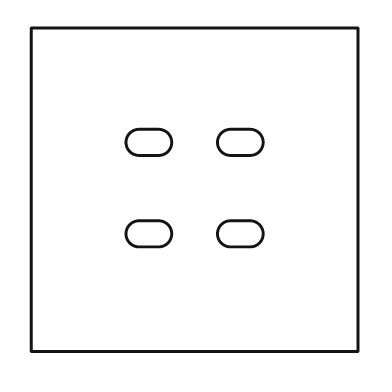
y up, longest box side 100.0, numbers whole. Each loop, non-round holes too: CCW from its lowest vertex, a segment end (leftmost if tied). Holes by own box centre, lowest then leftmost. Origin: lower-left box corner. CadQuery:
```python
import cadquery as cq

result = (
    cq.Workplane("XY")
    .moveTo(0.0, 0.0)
    .lineTo(100.0, 0.0)
    .lineTo(100.0, 99.0)
    .lineTo(0.0, 99.0)
    .close()
    .moveTo(33.0, 32.0)
    .lineTo(39.0, 32.0)
    .threePointArc((43.0, 36.0), (39.0, 40.0))
    .lineTo(33.0, 40.0)
    .threePointArc((29.0, 36.0), (33.0, 32.0))
    .close()
    .moveTo(61.0, 32.0)
    .lineTo(67.0, 32.0)
    .threePointArc((71.0, 36.0), (67.0, 40.0))
    .lineTo(61.0, 40.0)
    .threePointArc((57.0, 36.0), (61.0, 32.0))
    .close()
    .moveTo(33.0, 60.0)
    .lineTo(39.0, 60.0)
    .threePointArc((43.0, 64.0), (39.0, 68.0))
    .lineTo(33.0, 68.0)
    .threePointArc((29.0, 64.0), (33.0, 60.0))
    .close()
    .moveTo(61.0, 60.0)
    .lineTo(67.0, 60.0)
    .threePointArc((71.0, 64.0), (67.0, 68.0))
    .lineTo(61.0, 68.0)
    .threePointArc((57.0, 64.0), (61.0, 60.0))
    .close()
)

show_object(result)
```